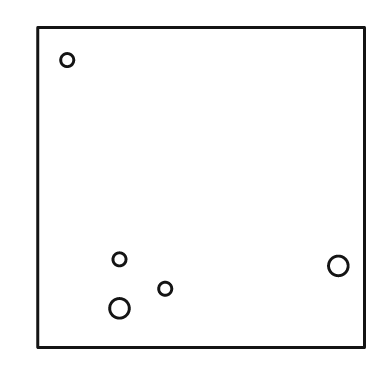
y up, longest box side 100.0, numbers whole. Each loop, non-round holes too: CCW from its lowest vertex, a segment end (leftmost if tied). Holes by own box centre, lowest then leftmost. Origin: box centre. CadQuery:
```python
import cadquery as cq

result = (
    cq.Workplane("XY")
    .moveTo(-50.0, -49.0)
    .lineTo(50.0, -49.0)
    .lineTo(50.0, 49.0)
    .lineTo(-50.0, 49.0)
    .close()
    .moveTo(-25.0, -37.0)
    .circle(3.0)
    .moveTo(-11.0, -31.0)
    .circle(2.0)
    .moveTo(42.0, -24.0)
    .circle(3.0)
    .moveTo(-25.0, -22.0)
    .circle(2.0)
    .moveTo(-41.0, 39.0)
    .circle(2.0)
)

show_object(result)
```